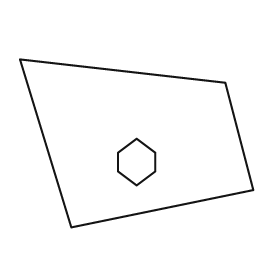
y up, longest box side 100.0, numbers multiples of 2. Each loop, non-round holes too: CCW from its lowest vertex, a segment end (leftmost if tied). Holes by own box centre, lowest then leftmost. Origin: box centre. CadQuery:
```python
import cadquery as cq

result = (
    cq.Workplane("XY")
    .moveTo(-28.0, -36.0)
    .lineTo(50.0, -20.0)
    .lineTo(38.0, 26.0)
    .lineTo(-50.0, 36.0)
    .close()
    .moveTo(0.0, -18.0)
    .lineTo(8.0, -12.0)
    .lineTo(8.0, -4.0)
    .lineTo(0.0, 2.0)
    .lineTo(-8.0, -4.0)
    .lineTo(-8.0, -12.0)
    .close()
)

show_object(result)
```